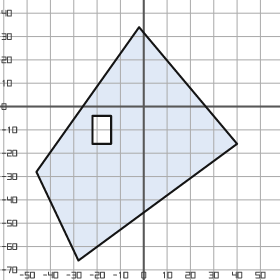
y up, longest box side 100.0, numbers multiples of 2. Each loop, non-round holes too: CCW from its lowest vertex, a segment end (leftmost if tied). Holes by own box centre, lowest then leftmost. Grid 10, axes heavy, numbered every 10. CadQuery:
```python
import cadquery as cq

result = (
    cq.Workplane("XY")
    .moveTo(-28.0, -66.0)
    .lineTo(40.0, -16.0)
    .lineTo(-2.0, 34.0)
    .lineTo(-46.0, -28.0)
    .close()
    .moveTo(-22.0, -16.0)
    .lineTo(-14.0, -16.0)
    .lineTo(-14.0, -4.0)
    .lineTo(-22.0, -4.0)
    .close()
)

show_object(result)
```